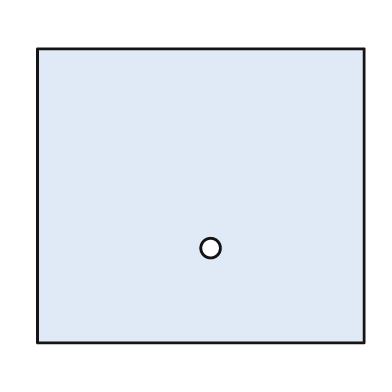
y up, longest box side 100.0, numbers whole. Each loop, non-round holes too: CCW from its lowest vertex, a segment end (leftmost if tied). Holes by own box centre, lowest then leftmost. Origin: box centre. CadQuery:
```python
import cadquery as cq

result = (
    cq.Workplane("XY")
    .moveTo(-50.0, -45.0)
    .lineTo(50.0, -45.0)
    .lineTo(50.0, 45.0)
    .lineTo(-50.0, 45.0)
    .close()
    .moveTo(3.0, -16.0)
    .circle(3.0)
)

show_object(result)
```